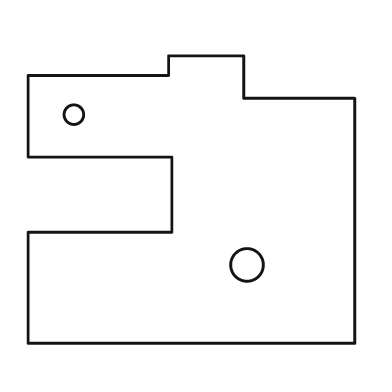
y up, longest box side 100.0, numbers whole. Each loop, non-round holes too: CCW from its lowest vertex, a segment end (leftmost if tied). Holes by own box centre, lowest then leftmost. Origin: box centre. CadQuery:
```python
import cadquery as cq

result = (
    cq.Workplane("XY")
    .moveTo(-50.0, -44.0)
    .lineTo(50.0, -44.0)
    .lineTo(50.0, 31.0)
    .lineTo(16.0, 31.0)
    .lineTo(16.0, 44.0)
    .lineTo(-7.0, 44.0)
    .lineTo(-7.0, 38.0)
    .lineTo(-50.0, 38.0)
    .lineTo(-50.0, 13.0)
    .lineTo(-6.0, 13.0)
    .lineTo(-6.0, -10.0)
    .lineTo(-50.0, -10.0)
    .close()
    .moveTo(17.0, -20.0)
    .circle(5.0)
    .moveTo(-36.0, 26.0)
    .circle(3.0)
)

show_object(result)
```